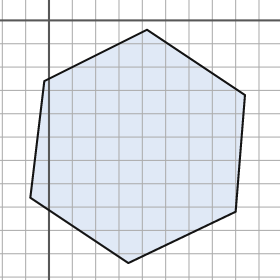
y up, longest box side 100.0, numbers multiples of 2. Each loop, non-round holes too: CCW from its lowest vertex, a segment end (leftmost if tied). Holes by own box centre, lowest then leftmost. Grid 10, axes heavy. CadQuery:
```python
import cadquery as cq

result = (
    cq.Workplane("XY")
    .moveTo(34.0, -104.0)
    .lineTo(80.0, -82.0)
    .lineTo(84.0, -32.0)
    .lineTo(42.0, -4.0)
    .lineTo(-2.0, -26.0)
    .lineTo(-8.0, -76.0)
    .close()
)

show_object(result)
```